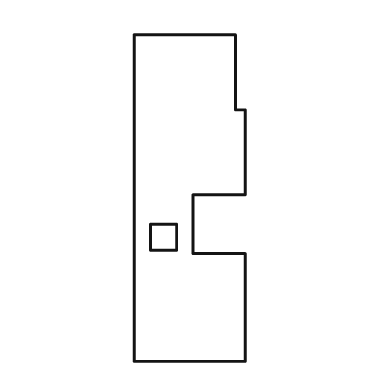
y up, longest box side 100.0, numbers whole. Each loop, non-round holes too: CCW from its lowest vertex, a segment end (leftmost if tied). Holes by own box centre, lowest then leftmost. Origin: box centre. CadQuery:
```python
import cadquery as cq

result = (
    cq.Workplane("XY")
    .moveTo(-17.0, -50.0)
    .lineTo(17.0, -50.0)
    .lineTo(17.0, -17.0)
    .lineTo(1.0, -17.0)
    .lineTo(1.0, 1.0)
    .lineTo(17.0, 1.0)
    .lineTo(17.0, 27.0)
    .lineTo(14.0, 27.0)
    .lineTo(14.0, 50.0)
    .lineTo(-17.0, 50.0)
    .close()
    .moveTo(-12.0, -16.0)
    .lineTo(-4.0, -16.0)
    .lineTo(-4.0, -8.0)
    .lineTo(-12.0, -8.0)
    .close()
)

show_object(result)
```